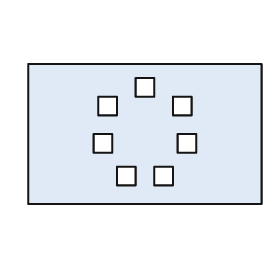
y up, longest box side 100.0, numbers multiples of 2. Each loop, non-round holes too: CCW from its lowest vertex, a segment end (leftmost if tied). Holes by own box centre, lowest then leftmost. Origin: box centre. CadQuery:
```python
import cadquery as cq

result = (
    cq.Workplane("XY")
    .moveTo(-50.0, -30.0)
    .lineTo(50.0, -30.0)
    .lineTo(50.0, 30.0)
    .lineTo(-50.0, 30.0)
    .close()
    .moveTo(-12.0, -22.0)
    .lineTo(-4.0, -22.0)
    .lineTo(-4.0, -14.0)
    .lineTo(-12.0, -14.0)
    .close()
    .moveTo(4.0, -22.0)
    .lineTo(12.0, -22.0)
    .lineTo(12.0, -14.0)
    .lineTo(4.0, -14.0)
    .close()
    .moveTo(-22.0, -8.0)
    .lineTo(-14.0, -8.0)
    .lineTo(-14.0, 0.0)
    .lineTo(-22.0, 0.0)
    .close()
    .moveTo(14.0, -8.0)
    .lineTo(22.0, -8.0)
    .lineTo(22.0, 0.0)
    .lineTo(14.0, 0.0)
    .close()
    .moveTo(-20.0, 8.0)
    .lineTo(-12.0, 8.0)
    .lineTo(-12.0, 16.0)
    .lineTo(-20.0, 16.0)
    .close()
    .moveTo(12.0, 8.0)
    .lineTo(20.0, 8.0)
    .lineTo(20.0, 16.0)
    .lineTo(12.0, 16.0)
    .close()
    .moveTo(-4.0, 16.0)
    .lineTo(4.0, 16.0)
    .lineTo(4.0, 24.0)
    .lineTo(-4.0, 24.0)
    .close()
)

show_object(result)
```